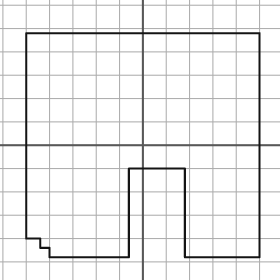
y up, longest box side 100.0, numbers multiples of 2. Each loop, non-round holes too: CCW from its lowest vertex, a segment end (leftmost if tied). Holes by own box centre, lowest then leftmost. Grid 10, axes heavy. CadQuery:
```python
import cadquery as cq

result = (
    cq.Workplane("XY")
    .moveTo(-40.0, -48.0)
    .lineTo(-6.0, -48.0)
    .lineTo(-6.0, -10.0)
    .lineTo(18.0, -10.0)
    .lineTo(18.0, -48.0)
    .lineTo(50.0, -48.0)
    .lineTo(50.0, 48.0)
    .lineTo(-50.0, 48.0)
    .lineTo(-50.0, -40.0)
    .lineTo(-44.0, -40.0)
    .lineTo(-44.0, -44.0)
    .lineTo(-40.0, -44.0)
    .close()
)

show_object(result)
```